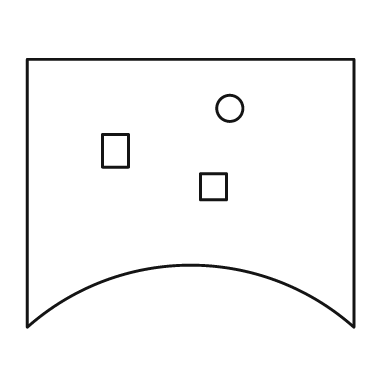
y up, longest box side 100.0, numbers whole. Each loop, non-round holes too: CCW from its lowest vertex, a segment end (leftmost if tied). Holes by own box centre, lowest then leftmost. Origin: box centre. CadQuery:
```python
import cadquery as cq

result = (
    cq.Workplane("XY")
    .moveTo(-50.0, -41.0)
    .threePointArc((0.0, -22.0), (50.0, -41.0))
    .lineTo(50.0, 41.0)
    .lineTo(-50.0, 41.0)
    .close()
    .moveTo(3.0, -2.0)
    .lineTo(11.0, -2.0)
    .lineTo(11.0, 6.0)
    .lineTo(3.0, 6.0)
    .close()
    .moveTo(-27.0, 8.0)
    .lineTo(-19.0, 8.0)
    .lineTo(-19.0, 18.0)
    .lineTo(-27.0, 18.0)
    .close()
    .moveTo(12.0, 26.0)
    .circle(4.0)
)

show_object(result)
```